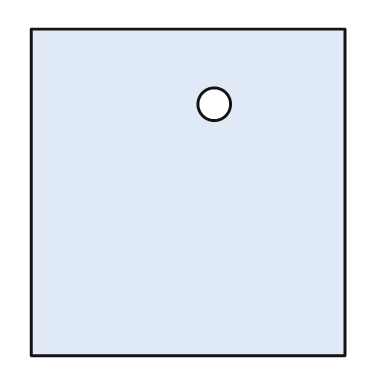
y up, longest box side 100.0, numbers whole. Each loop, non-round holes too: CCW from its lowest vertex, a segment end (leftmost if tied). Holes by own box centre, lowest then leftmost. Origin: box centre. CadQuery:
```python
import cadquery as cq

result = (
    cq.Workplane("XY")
    .moveTo(-48.0, -50.0)
    .lineTo(48.0, -50.0)
    .lineTo(48.0, 50.0)
    .lineTo(-48.0, 50.0)
    .close()
    .moveTo(8.0, 27.0)
    .circle(5.0)
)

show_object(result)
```